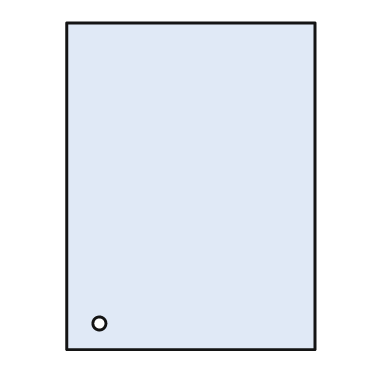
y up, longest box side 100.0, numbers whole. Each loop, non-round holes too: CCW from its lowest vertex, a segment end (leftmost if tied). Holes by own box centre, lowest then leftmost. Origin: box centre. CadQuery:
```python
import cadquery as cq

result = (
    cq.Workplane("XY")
    .moveTo(-38.0, -50.0)
    .lineTo(38.0, -50.0)
    .lineTo(38.0, 50.0)
    .lineTo(-38.0, 50.0)
    .close()
    .moveTo(-28.0, -42.0)
    .circle(2.0)
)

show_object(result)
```